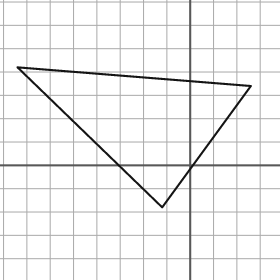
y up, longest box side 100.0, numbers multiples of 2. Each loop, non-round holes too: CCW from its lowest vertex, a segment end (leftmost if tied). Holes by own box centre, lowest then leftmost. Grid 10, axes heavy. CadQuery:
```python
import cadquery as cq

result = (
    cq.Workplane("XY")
    .moveTo(-12.0, -18.0)
    .lineTo(26.0, 34.0)
    .lineTo(-74.0, 42.0)
    .close()
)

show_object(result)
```